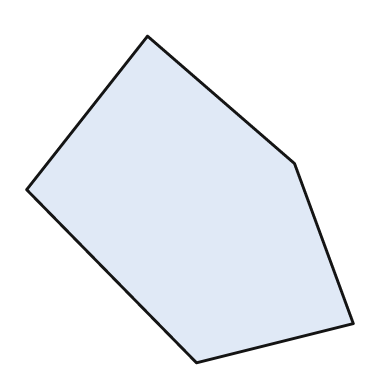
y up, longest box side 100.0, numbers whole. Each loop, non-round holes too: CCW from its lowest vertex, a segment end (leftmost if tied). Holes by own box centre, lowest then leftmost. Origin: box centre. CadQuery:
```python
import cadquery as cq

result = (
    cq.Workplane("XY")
    .moveTo(2.0, -50.0)
    .lineTo(50.0, -38.0)
    .lineTo(32.0, 11.0)
    .lineTo(-13.0, 50.0)
    .lineTo(-50.0, 3.0)
    .close()
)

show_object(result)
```